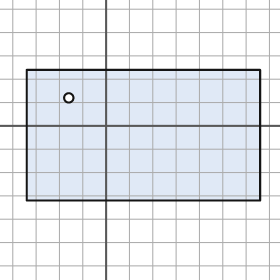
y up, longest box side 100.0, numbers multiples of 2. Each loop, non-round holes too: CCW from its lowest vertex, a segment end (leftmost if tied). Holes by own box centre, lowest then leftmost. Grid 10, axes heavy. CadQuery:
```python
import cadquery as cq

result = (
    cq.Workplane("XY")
    .moveTo(-34.0, -32.0)
    .lineTo(66.0, -32.0)
    .lineTo(66.0, 24.0)
    .lineTo(-34.0, 24.0)
    .close()
    .moveTo(-16.0, 12.0)
    .circle(2.0)
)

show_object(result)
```